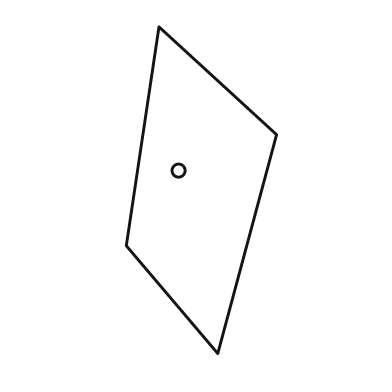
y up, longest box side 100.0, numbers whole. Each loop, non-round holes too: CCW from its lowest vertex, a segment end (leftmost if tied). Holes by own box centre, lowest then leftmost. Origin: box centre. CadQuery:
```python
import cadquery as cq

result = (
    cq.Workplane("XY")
    .moveTo(5.0, -50.0)
    .lineTo(23.0, 17.0)
    .lineTo(-13.0, 50.0)
    .lineTo(-23.0, -17.0)
    .close()
    .moveTo(-7.0, 6.0)
    .circle(2.0)
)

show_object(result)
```